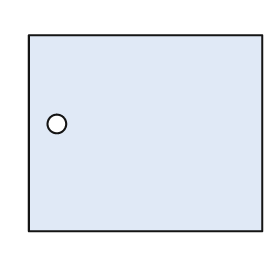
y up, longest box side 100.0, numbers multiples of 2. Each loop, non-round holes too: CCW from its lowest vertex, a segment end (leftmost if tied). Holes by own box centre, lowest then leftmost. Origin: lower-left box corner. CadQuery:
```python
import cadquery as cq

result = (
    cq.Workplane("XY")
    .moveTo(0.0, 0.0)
    .lineTo(100.0, 0.0)
    .lineTo(100.0, 84.0)
    .lineTo(0.0, 84.0)
    .close()
    .moveTo(12.0, 46.0)
    .circle(4.0)
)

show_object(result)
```